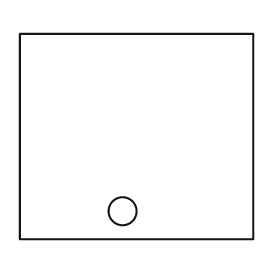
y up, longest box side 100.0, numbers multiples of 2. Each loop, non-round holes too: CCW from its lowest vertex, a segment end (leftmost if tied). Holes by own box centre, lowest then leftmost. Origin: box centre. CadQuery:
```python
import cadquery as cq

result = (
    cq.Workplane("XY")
    .moveTo(-50.0, -44.0)
    .lineTo(50.0, -44.0)
    .lineTo(50.0, 44.0)
    .lineTo(-50.0, 44.0)
    .close()
    .moveTo(-6.0, -32.0)
    .circle(6.0)
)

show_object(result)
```